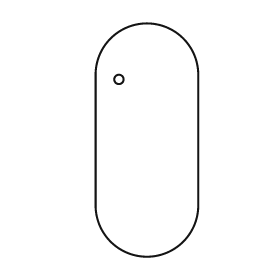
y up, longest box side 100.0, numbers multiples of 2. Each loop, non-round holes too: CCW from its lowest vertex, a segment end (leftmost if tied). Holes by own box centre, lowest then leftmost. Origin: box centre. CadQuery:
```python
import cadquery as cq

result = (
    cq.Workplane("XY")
    .moveTo(-22.0, -28.0)
    .threePointArc((0.0, -50.0), (22.0, -28.0))
    .lineTo(22.0, 28.0)
    .threePointArc((0.0, 50.0), (-22.0, 28.0))
    .close()
    .moveTo(-12.0, 26.0)
    .circle(2.0)
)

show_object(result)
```